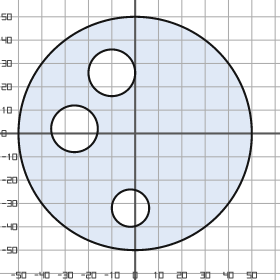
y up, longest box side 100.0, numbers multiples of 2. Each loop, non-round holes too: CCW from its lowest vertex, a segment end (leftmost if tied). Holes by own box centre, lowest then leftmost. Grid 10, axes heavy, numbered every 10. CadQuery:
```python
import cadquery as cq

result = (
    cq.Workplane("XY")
    .moveTo(0.0, 0.0)
    .circle(50.0)
    .moveTo(-2.0, -32.0)
    .circle(8.0)
    .moveTo(-26.0, 2.0)
    .circle(10.0)
    .moveTo(-10.0, 26.0)
    .circle(10.0)
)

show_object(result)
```